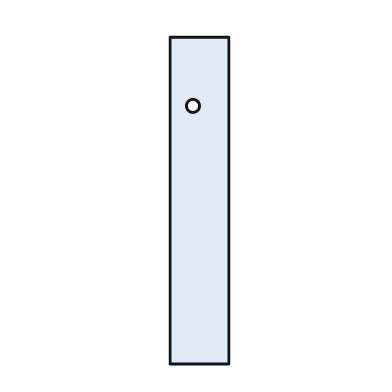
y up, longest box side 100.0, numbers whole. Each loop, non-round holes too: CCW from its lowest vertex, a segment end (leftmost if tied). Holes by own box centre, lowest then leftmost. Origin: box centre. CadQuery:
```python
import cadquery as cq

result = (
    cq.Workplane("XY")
    .moveTo(-9.0, -50.0)
    .lineTo(9.0, -50.0)
    .lineTo(9.0, 50.0)
    .lineTo(-9.0, 50.0)
    .close()
    .moveTo(-2.0, 29.0)
    .circle(2.0)
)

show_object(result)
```